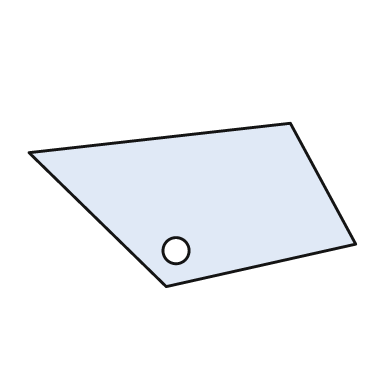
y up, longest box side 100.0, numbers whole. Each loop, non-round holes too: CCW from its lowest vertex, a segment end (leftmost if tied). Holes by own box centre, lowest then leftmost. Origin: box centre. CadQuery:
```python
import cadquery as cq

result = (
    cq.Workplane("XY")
    .moveTo(-8.0, -25.0)
    .lineTo(50.0, -12.0)
    .lineTo(30.0, 25.0)
    .lineTo(-50.0, 16.0)
    .close()
    .moveTo(-5.0, -14.0)
    .circle(4.0)
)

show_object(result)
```